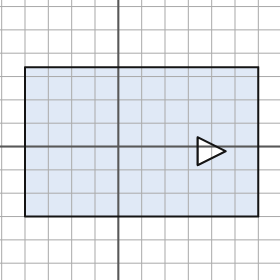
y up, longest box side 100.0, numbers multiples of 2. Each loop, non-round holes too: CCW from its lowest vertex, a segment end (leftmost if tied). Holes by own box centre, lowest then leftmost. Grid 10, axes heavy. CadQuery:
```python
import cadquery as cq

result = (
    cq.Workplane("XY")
    .moveTo(-40.0, -30.0)
    .lineTo(60.0, -30.0)
    .lineTo(60.0, 34.0)
    .lineTo(-40.0, 34.0)
    .close()
    .moveTo(34.0, -8.0)
    .lineTo(46.0, -2.0)
    .lineTo(34.0, 4.0)
    .close()
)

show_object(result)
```